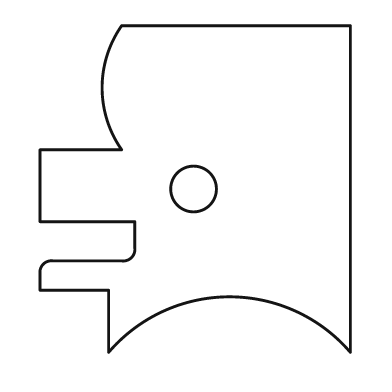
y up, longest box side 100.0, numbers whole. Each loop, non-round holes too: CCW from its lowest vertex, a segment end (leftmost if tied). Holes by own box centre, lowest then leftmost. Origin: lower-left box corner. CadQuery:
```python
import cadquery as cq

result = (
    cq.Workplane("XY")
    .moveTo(21.0, 0.0)
    .threePointArc((58.0, 17.0), (95.0, 0.0))
    .lineTo(95.0, 100.0)
    .lineTo(25.0, 100.0)
    .threePointArc((19.0, 81.0), (25.0, 62.0))
    .lineTo(0.0, 62.0)
    .lineTo(0.0, 40.0)
    .lineTo(29.0, 40.0)
    .lineTo(29.0, 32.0)
    .threePointArc((28.0, 29.0), (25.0, 28.0))
    .lineTo(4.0, 28.0)
    .threePointArc((1.0, 27.0), (0.0, 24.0))
    .lineTo(0.0, 19.0)
    .lineTo(21.0, 19.0)
    .close()
    .moveTo(47.0, 50.0)
    .circle(7.0)
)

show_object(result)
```